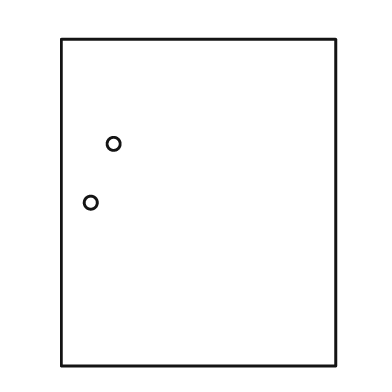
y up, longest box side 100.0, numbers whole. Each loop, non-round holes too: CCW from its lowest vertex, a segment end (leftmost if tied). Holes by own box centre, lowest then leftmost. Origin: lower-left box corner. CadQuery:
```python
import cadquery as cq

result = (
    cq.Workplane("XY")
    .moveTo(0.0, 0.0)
    .lineTo(84.0, 0.0)
    .lineTo(84.0, 100.0)
    .lineTo(0.0, 100.0)
    .close()
    .moveTo(9.0, 50.0)
    .circle(2.0)
    .moveTo(16.0, 68.0)
    .circle(2.0)
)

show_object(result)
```